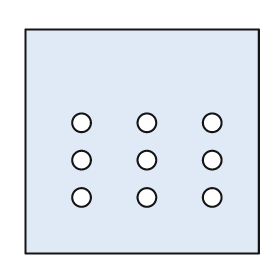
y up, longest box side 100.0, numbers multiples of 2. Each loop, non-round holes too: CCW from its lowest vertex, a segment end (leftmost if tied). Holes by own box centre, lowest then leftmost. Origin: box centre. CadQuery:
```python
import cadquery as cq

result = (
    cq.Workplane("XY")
    .moveTo(-50.0, -48.0)
    .lineTo(50.0, -48.0)
    .lineTo(50.0, 48.0)
    .lineTo(-50.0, 48.0)
    .close()
    .moveTo(-26.0, -24.0)
    .circle(4.0)
    .moveTo(2.0, -24.0)
    .circle(4.0)
    .moveTo(30.0, -24.0)
    .circle(4.0)
    .moveTo(-26.0, -8.0)
    .circle(4.0)
    .moveTo(2.0, -8.0)
    .circle(4.0)
    .moveTo(30.0, -8.0)
    .circle(4.0)
    .moveTo(-26.0, 8.0)
    .circle(4.0)
    .moveTo(2.0, 8.0)
    .circle(4.0)
    .moveTo(30.0, 8.0)
    .circle(4.0)
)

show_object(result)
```